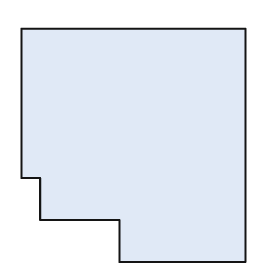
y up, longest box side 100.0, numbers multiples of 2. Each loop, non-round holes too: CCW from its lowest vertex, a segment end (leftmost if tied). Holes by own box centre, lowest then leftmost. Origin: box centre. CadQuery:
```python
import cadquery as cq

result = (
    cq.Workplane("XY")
    .moveTo(-6.0, -50.0)
    .lineTo(48.0, -50.0)
    .lineTo(48.0, 50.0)
    .lineTo(-48.0, 50.0)
    .lineTo(-48.0, -14.0)
    .lineTo(-40.0, -14.0)
    .lineTo(-40.0, -32.0)
    .lineTo(-6.0, -32.0)
    .close()
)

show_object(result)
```